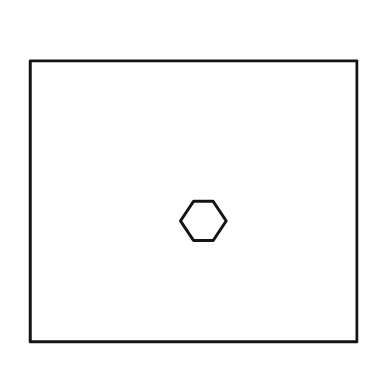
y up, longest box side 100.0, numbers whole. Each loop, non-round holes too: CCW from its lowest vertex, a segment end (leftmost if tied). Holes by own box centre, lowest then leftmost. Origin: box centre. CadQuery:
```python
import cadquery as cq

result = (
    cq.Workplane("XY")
    .moveTo(-50.0, -43.0)
    .lineTo(50.0, -43.0)
    .lineTo(50.0, 43.0)
    .lineTo(-50.0, 43.0)
    .close()
    .moveTo(0.0, -12.0)
    .lineTo(6.0, -12.0)
    .lineTo(10.0, -6.0)
    .lineTo(6.0, 0.0)
    .lineTo(0.0, 0.0)
    .lineTo(-4.0, -6.0)
    .close()
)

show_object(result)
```